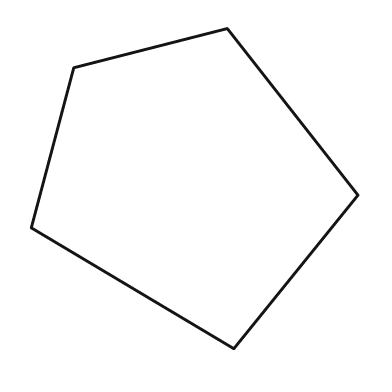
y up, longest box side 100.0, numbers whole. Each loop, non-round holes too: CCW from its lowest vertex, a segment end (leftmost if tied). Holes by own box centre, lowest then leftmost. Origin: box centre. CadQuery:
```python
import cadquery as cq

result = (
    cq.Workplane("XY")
    .moveTo(12.0, -49.0)
    .lineTo(50.0, -2.0)
    .lineTo(10.0, 49.0)
    .lineTo(-37.0, 37.0)
    .lineTo(-50.0, -12.0)
    .close()
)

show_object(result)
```